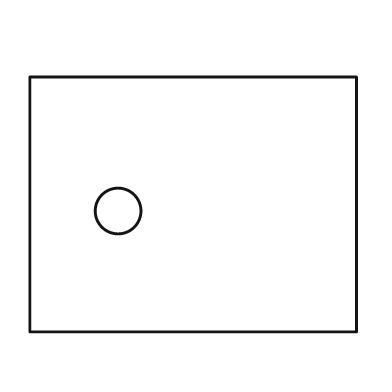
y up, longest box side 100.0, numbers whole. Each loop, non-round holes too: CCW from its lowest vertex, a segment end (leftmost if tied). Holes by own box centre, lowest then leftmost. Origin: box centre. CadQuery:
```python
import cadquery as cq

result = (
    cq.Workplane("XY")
    .moveTo(-50.0, -39.0)
    .lineTo(50.0, -39.0)
    .lineTo(50.0, 39.0)
    .lineTo(-50.0, 39.0)
    .close()
    .moveTo(-23.0, -2.0)
    .circle(7.0)
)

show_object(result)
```